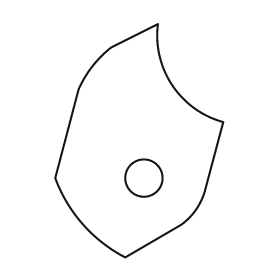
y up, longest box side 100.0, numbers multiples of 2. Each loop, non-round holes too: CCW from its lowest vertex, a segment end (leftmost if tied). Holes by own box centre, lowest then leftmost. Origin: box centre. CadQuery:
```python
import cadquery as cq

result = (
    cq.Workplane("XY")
    .moveTo(-6.0, -50.0)
    .lineTo(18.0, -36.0)
    .threePointArc((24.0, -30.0), (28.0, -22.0))
    .lineTo(36.0, 8.0)
    .threePointArc((14.0, 24.0), (8.0, 50.0))
    .lineTo(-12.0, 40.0)
    .threePointArc((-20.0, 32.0), (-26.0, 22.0))
    .lineTo(-36.0, -16.0)
    .threePointArc((-24.0, -36.0), (-6.0, -50.0))
    .close()
    .moveTo(2.0, -16.0)
    .circle(8.0)
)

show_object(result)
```